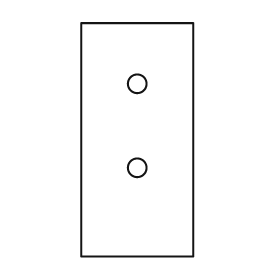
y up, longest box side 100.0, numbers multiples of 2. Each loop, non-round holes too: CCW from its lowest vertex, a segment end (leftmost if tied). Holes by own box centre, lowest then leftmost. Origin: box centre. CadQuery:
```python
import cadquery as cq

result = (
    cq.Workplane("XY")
    .moveTo(-24.0, -50.0)
    .lineTo(24.0, -50.0)
    .lineTo(24.0, 50.0)
    .lineTo(-24.0, 50.0)
    .close()
    .moveTo(0.0, -12.0)
    .circle(4.0)
    .moveTo(0.0, 24.0)
    .circle(4.0)
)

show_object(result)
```